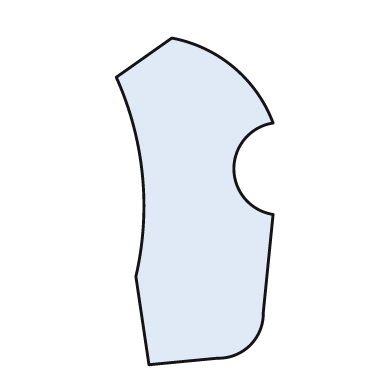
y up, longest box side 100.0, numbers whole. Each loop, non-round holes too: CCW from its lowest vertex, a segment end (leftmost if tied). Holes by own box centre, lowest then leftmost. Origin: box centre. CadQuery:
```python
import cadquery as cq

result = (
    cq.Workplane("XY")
    .moveTo(-14.0, -50.0)
    .lineTo(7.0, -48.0)
    .threePointArc((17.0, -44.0), (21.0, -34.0))
    .lineTo(24.0, -4.0)
    .threePointArc((12.0, 10.0), (24.0, 24.0))
    .threePointArc((12.0, 41.0), (-7.0, 50.0))
    .lineTo(-24.0, 38.0)
    .threePointArc((-16.0, 8.0), (-18.0, -23.0))
    .close()
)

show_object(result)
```